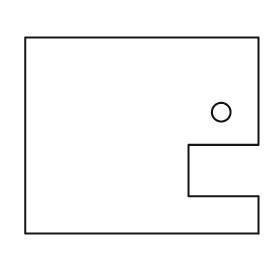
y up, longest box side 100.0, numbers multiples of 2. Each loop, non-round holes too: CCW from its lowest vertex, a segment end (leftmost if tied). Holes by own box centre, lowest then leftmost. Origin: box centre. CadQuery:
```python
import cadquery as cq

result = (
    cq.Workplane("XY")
    .moveTo(-50.0, -42.0)
    .lineTo(50.0, -42.0)
    .lineTo(50.0, -26.0)
    .lineTo(20.0, -26.0)
    .lineTo(20.0, -4.0)
    .lineTo(50.0, -4.0)
    .lineTo(50.0, 42.0)
    .lineTo(-50.0, 42.0)
    .close()
    .moveTo(34.0, 10.0)
    .circle(4.0)
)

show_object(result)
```